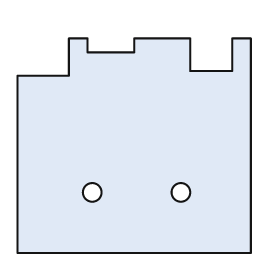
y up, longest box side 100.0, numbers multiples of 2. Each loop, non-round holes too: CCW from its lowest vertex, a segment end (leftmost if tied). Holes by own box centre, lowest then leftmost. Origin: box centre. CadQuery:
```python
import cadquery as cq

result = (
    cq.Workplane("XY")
    .moveTo(-50.0, -46.0)
    .lineTo(50.0, -46.0)
    .lineTo(50.0, 46.0)
    .lineTo(42.0, 46.0)
    .lineTo(42.0, 32.0)
    .lineTo(24.0, 32.0)
    .lineTo(24.0, 46.0)
    .lineTo(0.0, 46.0)
    .lineTo(0.0, 40.0)
    .lineTo(-20.0, 40.0)
    .lineTo(-20.0, 46.0)
    .lineTo(-28.0, 46.0)
    .lineTo(-28.0, 30.0)
    .lineTo(-50.0, 30.0)
    .close()
    .moveTo(-18.0, -20.0)
    .circle(4.0)
    .moveTo(20.0, -20.0)
    .circle(4.0)
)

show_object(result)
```